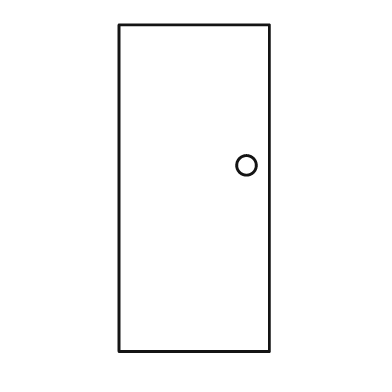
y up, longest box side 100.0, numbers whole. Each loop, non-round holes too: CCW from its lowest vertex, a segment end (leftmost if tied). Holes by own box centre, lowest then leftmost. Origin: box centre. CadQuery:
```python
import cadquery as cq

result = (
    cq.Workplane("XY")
    .moveTo(-23.0, -50.0)
    .lineTo(23.0, -50.0)
    .lineTo(23.0, 50.0)
    .lineTo(-23.0, 50.0)
    .close()
    .moveTo(16.0, 7.0)
    .circle(3.0)
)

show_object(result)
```